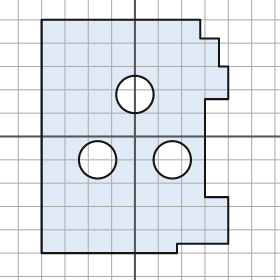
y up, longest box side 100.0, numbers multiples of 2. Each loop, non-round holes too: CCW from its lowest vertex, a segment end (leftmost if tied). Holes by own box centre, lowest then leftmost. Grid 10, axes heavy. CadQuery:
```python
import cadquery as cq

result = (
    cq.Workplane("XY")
    .moveTo(-40.0, -50.0)
    .lineTo(18.0, -50.0)
    .lineTo(18.0, -46.0)
    .lineTo(40.0, -46.0)
    .lineTo(40.0, -26.0)
    .lineTo(30.0, -26.0)
    .lineTo(30.0, 16.0)
    .lineTo(40.0, 16.0)
    .lineTo(40.0, 30.0)
    .lineTo(36.0, 30.0)
    .lineTo(36.0, 42.0)
    .lineTo(28.0, 42.0)
    .lineTo(28.0, 50.0)
    .lineTo(-40.0, 50.0)
    .close()
    .moveTo(-16.0, -10.0)
    .circle(8.0)
    .moveTo(16.0, -10.0)
    .circle(8.0)
    .moveTo(0.0, 18.0)
    .circle(8.0)
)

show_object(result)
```